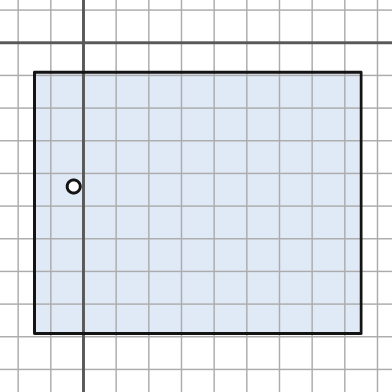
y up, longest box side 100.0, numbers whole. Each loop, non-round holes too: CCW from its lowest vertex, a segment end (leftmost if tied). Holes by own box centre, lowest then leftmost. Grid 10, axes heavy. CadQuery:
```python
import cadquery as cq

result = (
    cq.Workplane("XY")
    .moveTo(-15.0, -89.0)
    .lineTo(85.0, -89.0)
    .lineTo(85.0, -9.0)
    .lineTo(-15.0, -9.0)
    .close()
    .moveTo(-3.0, -44.0)
    .circle(2.0)
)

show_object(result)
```